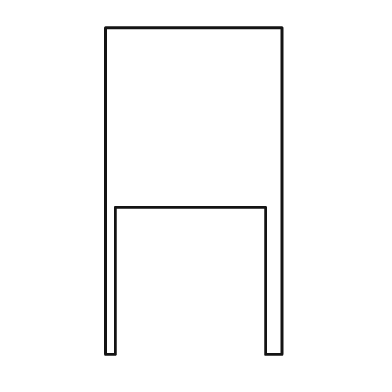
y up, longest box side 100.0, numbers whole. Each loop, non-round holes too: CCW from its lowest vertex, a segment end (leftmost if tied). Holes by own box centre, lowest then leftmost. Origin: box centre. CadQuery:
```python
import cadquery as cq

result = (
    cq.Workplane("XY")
    .moveTo(-27.0, -50.0)
    .lineTo(-24.0, -50.0)
    .lineTo(-24.0, -5.0)
    .lineTo(22.0, -5.0)
    .lineTo(22.0, -50.0)
    .lineTo(27.0, -50.0)
    .lineTo(27.0, 50.0)
    .lineTo(-27.0, 50.0)
    .close()
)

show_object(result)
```